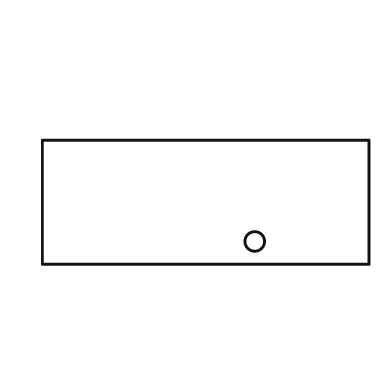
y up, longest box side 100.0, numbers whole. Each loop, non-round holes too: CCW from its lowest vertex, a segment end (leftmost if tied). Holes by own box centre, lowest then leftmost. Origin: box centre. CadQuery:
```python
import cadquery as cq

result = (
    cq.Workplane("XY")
    .moveTo(-50.0, -19.0)
    .lineTo(50.0, -19.0)
    .lineTo(50.0, 19.0)
    .lineTo(-50.0, 19.0)
    .close()
    .moveTo(15.0, -12.0)
    .circle(3.0)
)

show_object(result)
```